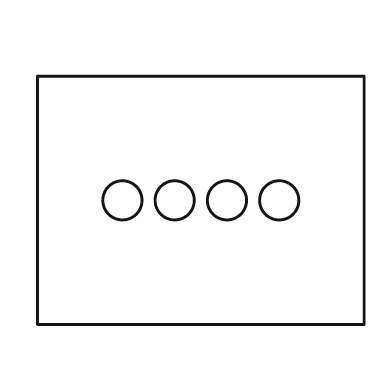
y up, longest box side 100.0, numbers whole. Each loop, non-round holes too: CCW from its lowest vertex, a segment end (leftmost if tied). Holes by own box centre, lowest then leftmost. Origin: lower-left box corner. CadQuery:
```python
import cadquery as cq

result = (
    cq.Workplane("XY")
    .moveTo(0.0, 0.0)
    .lineTo(100.0, 0.0)
    .lineTo(100.0, 76.0)
    .lineTo(0.0, 76.0)
    .close()
    .moveTo(26.0, 38.0)
    .circle(6.0)
    .moveTo(42.0, 38.0)
    .circle(6.0)
    .moveTo(58.0, 38.0)
    .circle(6.0)
    .moveTo(74.0, 38.0)
    .circle(6.0)
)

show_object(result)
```